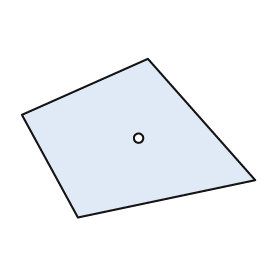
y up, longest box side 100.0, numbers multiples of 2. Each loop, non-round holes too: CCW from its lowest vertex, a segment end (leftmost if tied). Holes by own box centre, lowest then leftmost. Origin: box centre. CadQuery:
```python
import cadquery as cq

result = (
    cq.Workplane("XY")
    .moveTo(-26.0, -34.0)
    .lineTo(50.0, -18.0)
    .lineTo(4.0, 34.0)
    .lineTo(-50.0, 10.0)
    .close()
    .moveTo(0.0, 0.0)
    .circle(2.0)
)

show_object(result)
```